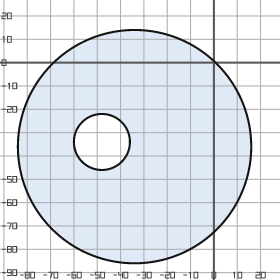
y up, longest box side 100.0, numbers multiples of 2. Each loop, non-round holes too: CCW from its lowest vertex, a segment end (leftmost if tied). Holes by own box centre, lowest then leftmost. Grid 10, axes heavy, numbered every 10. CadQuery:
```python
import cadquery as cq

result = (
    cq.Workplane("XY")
    .moveTo(-34.0, -36.0)
    .circle(50.0)
    .moveTo(-48.0, -34.0)
    .circle(12.0)
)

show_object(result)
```